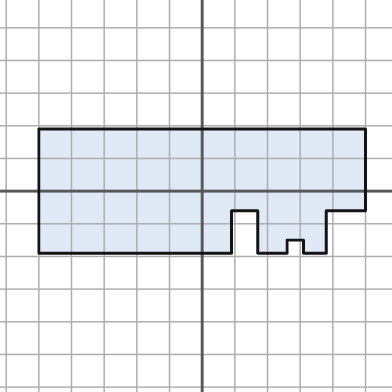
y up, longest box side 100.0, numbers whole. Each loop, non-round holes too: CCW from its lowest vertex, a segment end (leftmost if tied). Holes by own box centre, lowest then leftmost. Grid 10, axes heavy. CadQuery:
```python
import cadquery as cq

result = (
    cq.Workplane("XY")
    .moveTo(-50.0, -19.0)
    .lineTo(9.0, -19.0)
    .lineTo(9.0, -6.0)
    .lineTo(17.0, -6.0)
    .lineTo(17.0, -19.0)
    .lineTo(26.0, -19.0)
    .lineTo(26.0, -15.0)
    .lineTo(31.0, -15.0)
    .lineTo(31.0, -19.0)
    .lineTo(38.0, -19.0)
    .lineTo(38.0, -6.0)
    .lineTo(50.0, -6.0)
    .lineTo(50.0, 19.0)
    .lineTo(-50.0, 19.0)
    .close()
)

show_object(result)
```